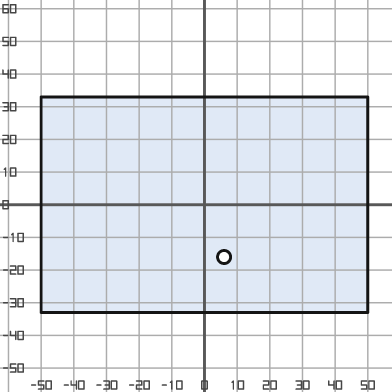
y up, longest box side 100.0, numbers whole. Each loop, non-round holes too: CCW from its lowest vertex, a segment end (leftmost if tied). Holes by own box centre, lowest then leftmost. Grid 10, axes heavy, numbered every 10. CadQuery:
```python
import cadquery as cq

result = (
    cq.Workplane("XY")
    .moveTo(-50.0, -33.0)
    .lineTo(50.0, -33.0)
    .lineTo(50.0, 33.0)
    .lineTo(-50.0, 33.0)
    .close()
    .moveTo(6.0, -16.0)
    .circle(2.0)
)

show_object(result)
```